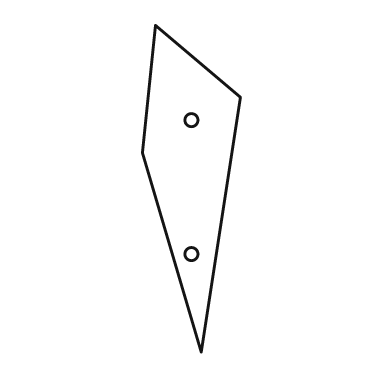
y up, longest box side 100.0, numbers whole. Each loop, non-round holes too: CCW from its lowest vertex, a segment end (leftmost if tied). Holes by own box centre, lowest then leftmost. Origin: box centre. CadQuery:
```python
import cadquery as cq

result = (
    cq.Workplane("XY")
    .moveTo(3.0, -50.0)
    .lineTo(15.0, 28.0)
    .lineTo(-11.0, 50.0)
    .lineTo(-15.0, 11.0)
    .close()
    .moveTo(0.0, -20.0)
    .circle(2.0)
    .moveTo(0.0, 21.0)
    .circle(2.0)
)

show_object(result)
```